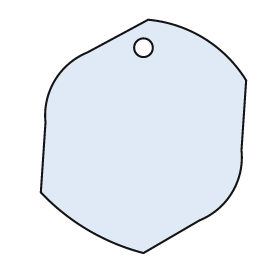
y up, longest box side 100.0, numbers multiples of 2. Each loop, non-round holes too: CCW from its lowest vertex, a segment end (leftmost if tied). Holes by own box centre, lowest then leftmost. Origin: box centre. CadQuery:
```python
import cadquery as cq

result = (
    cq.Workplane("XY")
    .moveTo(0.0, -50.0)
    .lineTo(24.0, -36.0)
    .threePointArc((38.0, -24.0), (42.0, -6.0))
    .lineTo(44.0, 24.0)
    .threePointArc((26.0, 42.0), (2.0, 50.0))
    .lineTo(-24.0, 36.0)
    .threePointArc((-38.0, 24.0), (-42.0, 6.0))
    .lineTo(-44.0, -24.0)
    .threePointArc((-24.0, -40.0), (0.0, -50.0))
    .close()
    .moveTo(0.0, 38.0)
    .circle(4.0)
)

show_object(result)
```